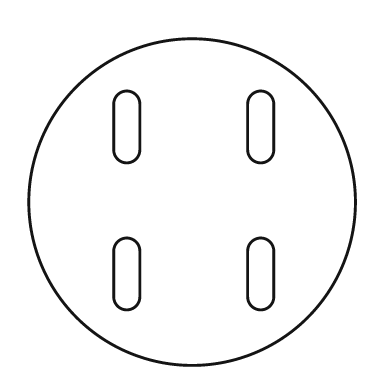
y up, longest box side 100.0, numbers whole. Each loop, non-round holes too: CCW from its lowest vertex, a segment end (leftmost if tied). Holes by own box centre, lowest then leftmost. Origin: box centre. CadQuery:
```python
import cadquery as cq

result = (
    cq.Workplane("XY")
    .moveTo(0.0, 0.0)
    .circle(50.0)
    .moveTo(-24.0, -29.0)
    .threePointArc((-20.0, -33.0), (-16.0, -29.0))
    .lineTo(-16.0, -15.0)
    .threePointArc((-20.0, -11.0), (-24.0, -15.0))
    .close()
    .moveTo(17.0, -29.0)
    .threePointArc((21.0, -33.0), (25.0, -29.0))
    .lineTo(25.0, -15.0)
    .threePointArc((21.0, -11.0), (17.0, -15.0))
    .close()
    .moveTo(-24.0, 16.0)
    .threePointArc((-20.0, 12.0), (-16.0, 16.0))
    .lineTo(-16.0, 30.0)
    .threePointArc((-20.0, 34.0), (-24.0, 30.0))
    .close()
    .moveTo(17.0, 16.0)
    .threePointArc((21.0, 12.0), (25.0, 16.0))
    .lineTo(25.0, 30.0)
    .threePointArc((21.0, 34.0), (17.0, 30.0))
    .close()
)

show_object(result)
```